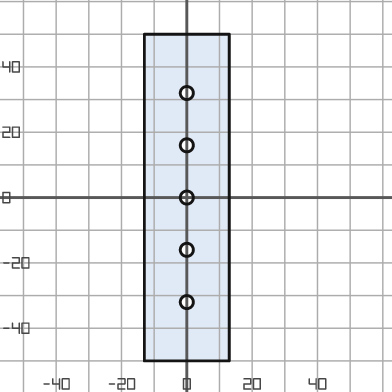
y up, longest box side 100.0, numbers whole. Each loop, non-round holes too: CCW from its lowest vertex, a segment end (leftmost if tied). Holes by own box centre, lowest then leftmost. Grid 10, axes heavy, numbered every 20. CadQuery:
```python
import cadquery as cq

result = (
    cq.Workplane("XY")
    .moveTo(-13.0, -50.0)
    .lineTo(13.0, -50.0)
    .lineTo(13.0, 50.0)
    .lineTo(-13.0, 50.0)
    .close()
    .moveTo(0.0, -32.0)
    .circle(2.0)
    .moveTo(0.0, -16.0)
    .circle(2.0)
    .moveTo(0.0, 0.0)
    .circle(2.0)
    .moveTo(0.0, 16.0)
    .circle(2.0)
    .moveTo(0.0, 32.0)
    .circle(2.0)
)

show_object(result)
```